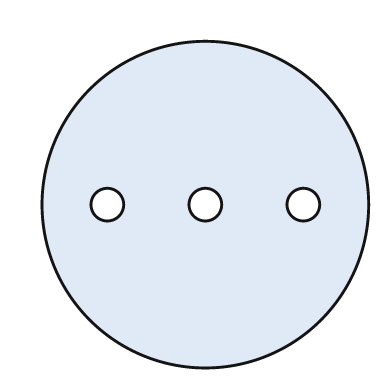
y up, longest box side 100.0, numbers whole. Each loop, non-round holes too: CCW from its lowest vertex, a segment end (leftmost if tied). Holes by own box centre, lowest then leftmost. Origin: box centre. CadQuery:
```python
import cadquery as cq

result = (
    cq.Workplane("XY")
    .moveTo(0.0, 0.0)
    .circle(50.0)
    .moveTo(-30.0, 0.0)
    .circle(5.0)
    .moveTo(0.0, 0.0)
    .circle(5.0)
    .moveTo(30.0, 0.0)
    .circle(5.0)
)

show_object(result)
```